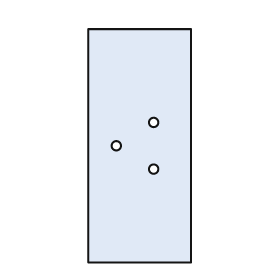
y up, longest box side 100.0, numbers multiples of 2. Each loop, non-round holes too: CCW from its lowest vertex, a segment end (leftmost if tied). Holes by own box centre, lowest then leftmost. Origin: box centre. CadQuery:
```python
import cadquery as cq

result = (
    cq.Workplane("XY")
    .moveTo(-22.0, -50.0)
    .lineTo(22.0, -50.0)
    .lineTo(22.0, 50.0)
    .lineTo(-22.0, 50.0)
    .close()
    .moveTo(6.0, -10.0)
    .circle(2.0)
    .moveTo(-10.0, 0.0)
    .circle(2.0)
    .moveTo(6.0, 10.0)
    .circle(2.0)
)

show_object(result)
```